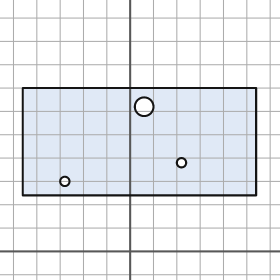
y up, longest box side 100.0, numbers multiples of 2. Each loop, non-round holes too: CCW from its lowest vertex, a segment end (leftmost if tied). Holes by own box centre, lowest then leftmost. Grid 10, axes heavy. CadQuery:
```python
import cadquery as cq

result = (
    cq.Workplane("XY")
    .moveTo(-46.0, 24.0)
    .lineTo(54.0, 24.0)
    .lineTo(54.0, 70.0)
    .lineTo(-46.0, 70.0)
    .close()
    .moveTo(-28.0, 30.0)
    .circle(2.0)
    .moveTo(22.0, 38.0)
    .circle(2.0)
    .moveTo(6.0, 62.0)
    .circle(4.0)
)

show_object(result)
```